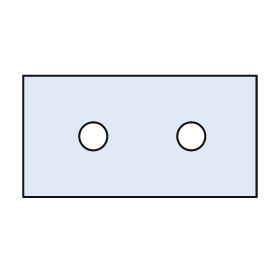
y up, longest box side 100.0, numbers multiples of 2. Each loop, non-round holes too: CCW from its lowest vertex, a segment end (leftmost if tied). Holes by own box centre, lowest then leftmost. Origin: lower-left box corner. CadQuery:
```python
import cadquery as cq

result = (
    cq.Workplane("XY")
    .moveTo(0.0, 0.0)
    .lineTo(100.0, 0.0)
    .lineTo(100.0, 52.0)
    .lineTo(0.0, 52.0)
    .close()
    .moveTo(30.0, 26.0)
    .circle(6.0)
    .moveTo(72.0, 26.0)
    .circle(6.0)
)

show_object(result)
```